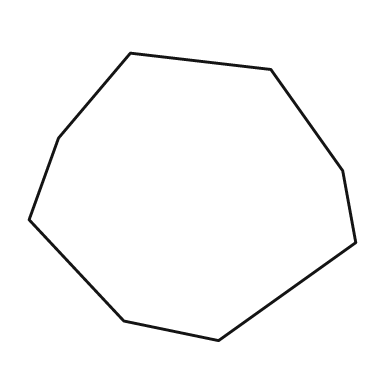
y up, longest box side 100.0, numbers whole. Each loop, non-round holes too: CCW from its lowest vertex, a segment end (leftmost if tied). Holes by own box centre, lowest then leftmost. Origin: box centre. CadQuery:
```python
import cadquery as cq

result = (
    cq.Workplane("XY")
    .moveTo(8.0, -44.0)
    .lineTo(50.0, -14.0)
    .lineTo(46.0, 8.0)
    .lineTo(24.0, 39.0)
    .lineTo(-19.0, 44.0)
    .lineTo(-41.0, 18.0)
    .lineTo(-50.0, -7.0)
    .lineTo(-21.0, -38.0)
    .close()
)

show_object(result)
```